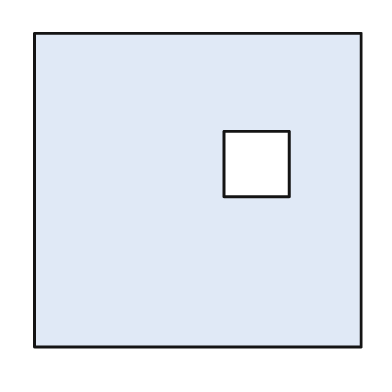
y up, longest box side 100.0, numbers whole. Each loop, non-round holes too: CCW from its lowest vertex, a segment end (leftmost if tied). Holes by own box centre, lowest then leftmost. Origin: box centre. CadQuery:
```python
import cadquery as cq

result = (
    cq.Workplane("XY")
    .moveTo(-50.0, -48.0)
    .lineTo(50.0, -48.0)
    .lineTo(50.0, 48.0)
    .lineTo(-50.0, 48.0)
    .close()
    .moveTo(8.0, -2.0)
    .lineTo(28.0, -2.0)
    .lineTo(28.0, 18.0)
    .lineTo(8.0, 18.0)
    .close()
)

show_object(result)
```